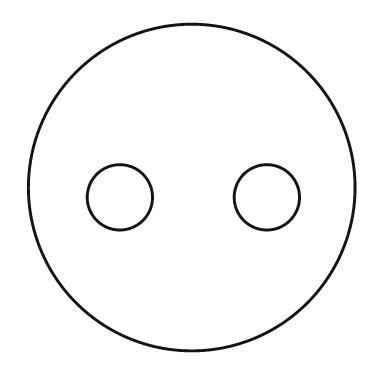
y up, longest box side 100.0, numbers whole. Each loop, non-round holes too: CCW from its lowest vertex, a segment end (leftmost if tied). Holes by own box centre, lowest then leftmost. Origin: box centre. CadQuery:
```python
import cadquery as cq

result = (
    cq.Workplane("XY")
    .moveTo(0.0, 0.0)
    .circle(50.0)
    .moveTo(-22.0, -3.0)
    .circle(10.0)
    .moveTo(23.0, -3.0)
    .circle(10.0)
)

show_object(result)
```